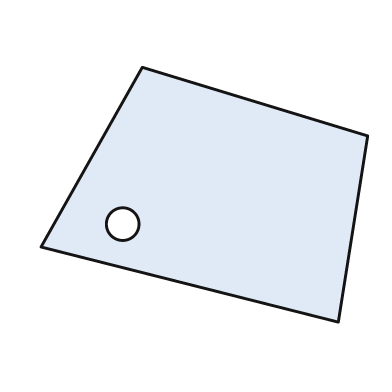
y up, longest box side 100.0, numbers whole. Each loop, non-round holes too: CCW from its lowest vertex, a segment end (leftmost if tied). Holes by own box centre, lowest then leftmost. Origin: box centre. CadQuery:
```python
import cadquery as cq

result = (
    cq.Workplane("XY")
    .moveTo(41.0, -39.0)
    .lineTo(50.0, 18.0)
    .lineTo(-19.0, 39.0)
    .lineTo(-50.0, -16.0)
    .close()
    .moveTo(-25.0, -9.0)
    .circle(5.0)
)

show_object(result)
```